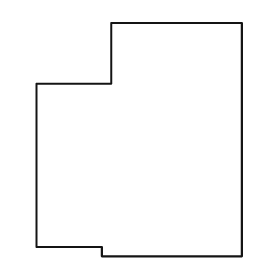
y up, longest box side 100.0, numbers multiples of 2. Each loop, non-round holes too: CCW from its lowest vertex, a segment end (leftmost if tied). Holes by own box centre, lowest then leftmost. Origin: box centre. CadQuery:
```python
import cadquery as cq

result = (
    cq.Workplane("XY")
    .moveTo(-16.0, -50.0)
    .lineTo(44.0, -50.0)
    .lineTo(44.0, 50.0)
    .lineTo(-12.0, 50.0)
    .lineTo(-12.0, 24.0)
    .lineTo(-44.0, 24.0)
    .lineTo(-44.0, -46.0)
    .lineTo(-16.0, -46.0)
    .close()
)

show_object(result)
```